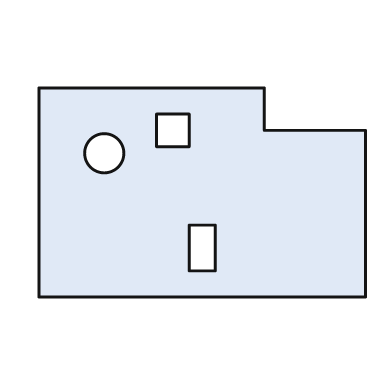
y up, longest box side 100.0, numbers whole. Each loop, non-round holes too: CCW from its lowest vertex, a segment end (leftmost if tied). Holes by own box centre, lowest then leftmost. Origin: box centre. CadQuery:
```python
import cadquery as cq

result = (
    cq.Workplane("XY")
    .moveTo(-50.0, -32.0)
    .lineTo(50.0, -32.0)
    .lineTo(50.0, 19.0)
    .lineTo(19.0, 19.0)
    .lineTo(19.0, 32.0)
    .lineTo(-50.0, 32.0)
    .close()
    .moveTo(-4.0, -24.0)
    .lineTo(4.0, -24.0)
    .lineTo(4.0, -10.0)
    .lineTo(-4.0, -10.0)
    .close()
    .moveTo(-30.0, 12.0)
    .circle(6.0)
    .moveTo(-14.0, 14.0)
    .lineTo(-4.0, 14.0)
    .lineTo(-4.0, 24.0)
    .lineTo(-14.0, 24.0)
    .close()
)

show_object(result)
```